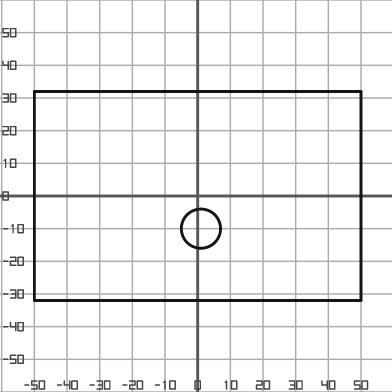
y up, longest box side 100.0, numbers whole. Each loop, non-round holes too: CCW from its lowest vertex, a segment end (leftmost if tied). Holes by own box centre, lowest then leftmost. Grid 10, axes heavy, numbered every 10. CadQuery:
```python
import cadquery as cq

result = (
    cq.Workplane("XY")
    .moveTo(-50.0, -32.0)
    .lineTo(50.0, -32.0)
    .lineTo(50.0, 32.0)
    .lineTo(-50.0, 32.0)
    .close()
    .moveTo(1.0, -10.0)
    .circle(6.0)
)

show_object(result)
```